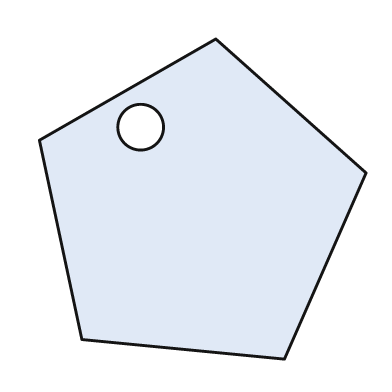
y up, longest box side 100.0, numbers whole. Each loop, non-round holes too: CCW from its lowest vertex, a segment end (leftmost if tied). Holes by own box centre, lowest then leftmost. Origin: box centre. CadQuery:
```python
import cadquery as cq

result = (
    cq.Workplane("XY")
    .moveTo(25.0, -49.0)
    .lineTo(50.0, 8.0)
    .lineTo(4.0, 49.0)
    .lineTo(-50.0, 18.0)
    .lineTo(-37.0, -43.0)
    .close()
    .moveTo(-19.0, 22.0)
    .circle(7.0)
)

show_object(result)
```